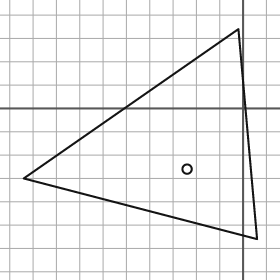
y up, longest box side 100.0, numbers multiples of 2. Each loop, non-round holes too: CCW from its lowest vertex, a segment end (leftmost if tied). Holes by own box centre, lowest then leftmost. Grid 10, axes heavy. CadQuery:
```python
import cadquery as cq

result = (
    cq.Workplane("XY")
    .moveTo(6.0, -56.0)
    .lineTo(-2.0, 34.0)
    .lineTo(-94.0, -30.0)
    .close()
    .moveTo(-24.0, -26.0)
    .circle(2.0)
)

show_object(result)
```